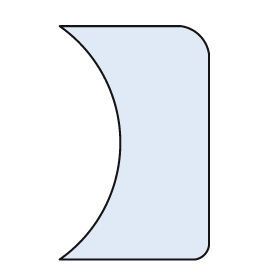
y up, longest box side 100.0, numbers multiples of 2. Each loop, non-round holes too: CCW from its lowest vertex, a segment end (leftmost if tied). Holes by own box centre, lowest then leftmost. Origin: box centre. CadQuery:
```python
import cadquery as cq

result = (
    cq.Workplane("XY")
    .moveTo(-32.0, -50.0)
    .lineTo(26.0, -50.0)
    .threePointArc((30.0, -48.0), (32.0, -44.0))
    .lineTo(32.0, 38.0)
    .threePointArc((28.0, 46.0), (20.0, 50.0))
    .lineTo(-32.0, 50.0)
    .threePointArc((-6.0, 0.0), (-32.0, -50.0))
    .close()
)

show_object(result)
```